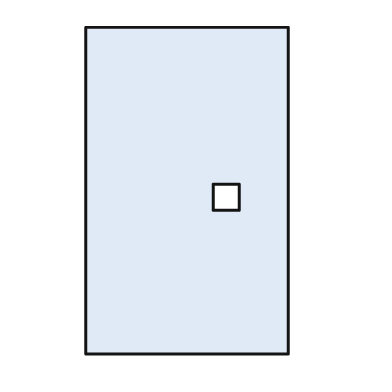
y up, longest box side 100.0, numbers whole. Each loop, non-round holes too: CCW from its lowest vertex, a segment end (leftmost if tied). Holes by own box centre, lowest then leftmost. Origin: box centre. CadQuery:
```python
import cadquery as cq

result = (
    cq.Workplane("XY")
    .moveTo(-31.0, -50.0)
    .lineTo(31.0, -50.0)
    .lineTo(31.0, 50.0)
    .lineTo(-31.0, 50.0)
    .close()
    .moveTo(8.0, -6.0)
    .lineTo(16.0, -6.0)
    .lineTo(16.0, 2.0)
    .lineTo(8.0, 2.0)
    .close()
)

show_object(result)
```